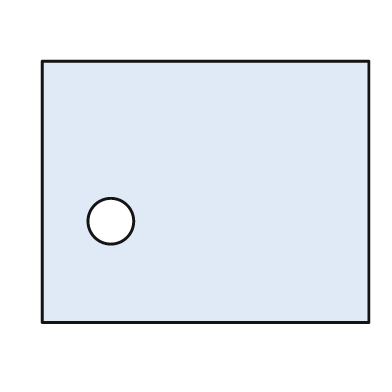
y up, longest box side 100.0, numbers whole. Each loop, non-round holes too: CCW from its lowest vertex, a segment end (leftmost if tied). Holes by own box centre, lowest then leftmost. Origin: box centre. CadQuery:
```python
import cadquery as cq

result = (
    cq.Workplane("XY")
    .moveTo(-50.0, -40.0)
    .lineTo(50.0, -40.0)
    .lineTo(50.0, 40.0)
    .lineTo(-50.0, 40.0)
    .close()
    .moveTo(-29.0, -9.0)
    .circle(7.0)
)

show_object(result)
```